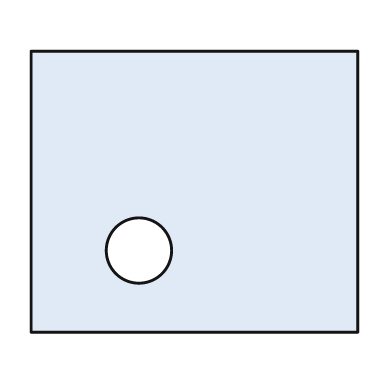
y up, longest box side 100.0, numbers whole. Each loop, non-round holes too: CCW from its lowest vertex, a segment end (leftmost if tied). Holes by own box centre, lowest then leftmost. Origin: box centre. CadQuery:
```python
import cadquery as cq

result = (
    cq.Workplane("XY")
    .moveTo(-50.0, -43.0)
    .lineTo(50.0, -43.0)
    .lineTo(50.0, 43.0)
    .lineTo(-50.0, 43.0)
    .close()
    .moveTo(-17.0, -18.0)
    .circle(10.0)
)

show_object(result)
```